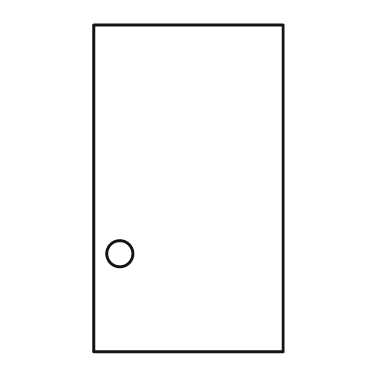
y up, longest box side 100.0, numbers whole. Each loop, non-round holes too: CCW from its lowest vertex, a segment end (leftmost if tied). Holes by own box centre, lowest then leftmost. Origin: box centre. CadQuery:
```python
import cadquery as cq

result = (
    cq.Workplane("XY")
    .moveTo(-29.0, -50.0)
    .lineTo(29.0, -50.0)
    .lineTo(29.0, 50.0)
    .lineTo(-29.0, 50.0)
    .close()
    .moveTo(-21.0, -20.0)
    .circle(4.0)
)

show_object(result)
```